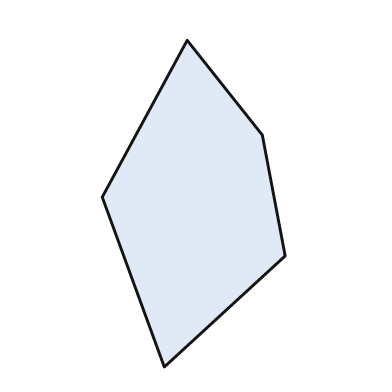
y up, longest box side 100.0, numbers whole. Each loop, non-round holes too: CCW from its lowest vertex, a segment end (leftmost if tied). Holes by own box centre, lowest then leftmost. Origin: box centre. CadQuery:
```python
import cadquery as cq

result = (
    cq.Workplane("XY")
    .moveTo(-9.0, -50.0)
    .lineTo(28.0, -16.0)
    .lineTo(21.0, 21.0)
    .lineTo(-2.0, 50.0)
    .lineTo(-28.0, 2.0)
    .close()
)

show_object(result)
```